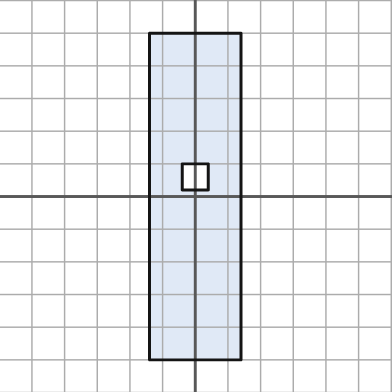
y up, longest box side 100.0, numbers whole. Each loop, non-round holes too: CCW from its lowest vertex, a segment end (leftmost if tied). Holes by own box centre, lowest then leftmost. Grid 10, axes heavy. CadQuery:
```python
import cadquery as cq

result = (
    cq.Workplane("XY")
    .moveTo(-14.0, -50.0)
    .lineTo(14.0, -50.0)
    .lineTo(14.0, 50.0)
    .lineTo(-14.0, 50.0)
    .close()
    .moveTo(-4.0, 2.0)
    .lineTo(4.0, 2.0)
    .lineTo(4.0, 10.0)
    .lineTo(-4.0, 10.0)
    .close()
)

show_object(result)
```